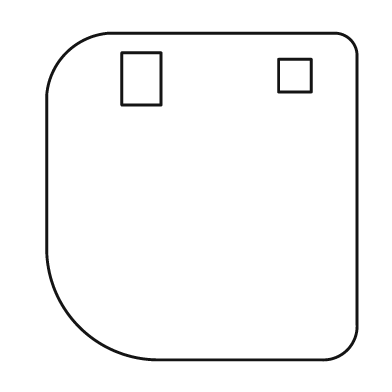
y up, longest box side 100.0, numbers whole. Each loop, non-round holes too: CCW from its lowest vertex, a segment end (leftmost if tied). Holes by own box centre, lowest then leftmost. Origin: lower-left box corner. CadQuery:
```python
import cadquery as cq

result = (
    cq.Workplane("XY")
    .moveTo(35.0, 0.0)
    .lineTo(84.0, 0.0)
    .threePointArc((92.0, 3.0), (95.0, 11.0))
    .lineTo(95.0, 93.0)
    .threePointArc((93.0, 98.0), (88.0, 100.0))
    .lineTo(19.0, 100.0)
    .threePointArc((6.0, 94.0), (0.0, 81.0))
    .lineTo(0.0, 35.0)
    .threePointArc((10.0, 10.0), (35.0, 0.0))
    .close()
    .moveTo(23.0, 78.0)
    .lineTo(35.0, 78.0)
    .lineTo(35.0, 94.0)
    .lineTo(23.0, 94.0)
    .close()
    .moveTo(71.0, 82.0)
    .lineTo(81.0, 82.0)
    .lineTo(81.0, 92.0)
    .lineTo(71.0, 92.0)
    .close()
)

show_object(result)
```